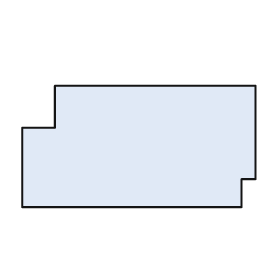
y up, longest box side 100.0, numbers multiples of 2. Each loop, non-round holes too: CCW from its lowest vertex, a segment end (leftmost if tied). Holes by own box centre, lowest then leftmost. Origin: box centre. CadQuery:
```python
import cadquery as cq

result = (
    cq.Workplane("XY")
    .moveTo(-50.0, -26.0)
    .lineTo(44.0, -26.0)
    .lineTo(44.0, -14.0)
    .lineTo(50.0, -14.0)
    .lineTo(50.0, 26.0)
    .lineTo(-36.0, 26.0)
    .lineTo(-36.0, 8.0)
    .lineTo(-50.0, 8.0)
    .close()
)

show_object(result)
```